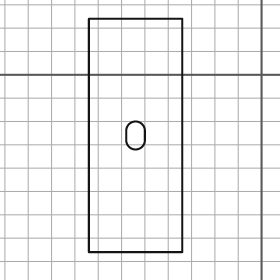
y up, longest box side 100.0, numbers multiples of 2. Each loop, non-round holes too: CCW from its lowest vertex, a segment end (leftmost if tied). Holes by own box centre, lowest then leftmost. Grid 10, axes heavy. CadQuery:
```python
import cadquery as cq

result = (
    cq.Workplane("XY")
    .moveTo(-74.0, -76.0)
    .lineTo(-34.0, -76.0)
    .lineTo(-34.0, 24.0)
    .lineTo(-74.0, 24.0)
    .close()
    .moveTo(-58.0, -28.0)
    .threePointArc((-54.0, -32.0), (-50.0, -28.0))
    .lineTo(-50.0, -24.0)
    .threePointArc((-54.0, -20.0), (-58.0, -24.0))
    .close()
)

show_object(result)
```